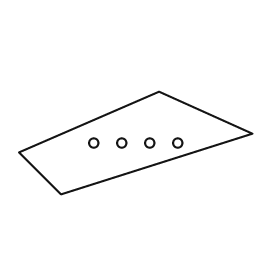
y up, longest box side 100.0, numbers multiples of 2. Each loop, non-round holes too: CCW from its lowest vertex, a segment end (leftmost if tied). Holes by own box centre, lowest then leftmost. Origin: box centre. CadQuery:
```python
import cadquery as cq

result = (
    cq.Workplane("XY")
    .moveTo(-32.0, -22.0)
    .lineTo(50.0, 4.0)
    .lineTo(10.0, 22.0)
    .lineTo(-50.0, -4.0)
    .close()
    .moveTo(-18.0, 0.0)
    .circle(2.0)
    .moveTo(-6.0, 0.0)
    .circle(2.0)
    .moveTo(6.0, 0.0)
    .circle(2.0)
    .moveTo(18.0, 0.0)
    .circle(2.0)
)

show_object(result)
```